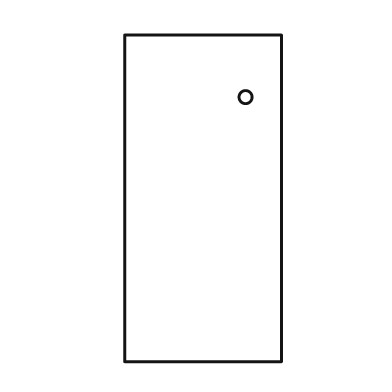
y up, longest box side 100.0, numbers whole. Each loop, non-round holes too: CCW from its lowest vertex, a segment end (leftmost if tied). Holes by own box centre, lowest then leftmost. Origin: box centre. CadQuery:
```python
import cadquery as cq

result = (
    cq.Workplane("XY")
    .moveTo(-24.0, -50.0)
    .lineTo(24.0, -50.0)
    .lineTo(24.0, 50.0)
    .lineTo(-24.0, 50.0)
    .close()
    .moveTo(13.0, 31.0)
    .circle(2.0)
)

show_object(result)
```